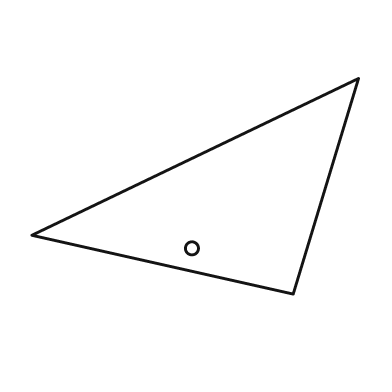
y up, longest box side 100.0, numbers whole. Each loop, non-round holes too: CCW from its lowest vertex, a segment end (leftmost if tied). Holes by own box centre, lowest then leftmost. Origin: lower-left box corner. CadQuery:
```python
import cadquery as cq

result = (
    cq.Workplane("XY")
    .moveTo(80.0, 0.0)
    .lineTo(100.0, 66.0)
    .lineTo(0.0, 18.0)
    .close()
    .moveTo(49.0, 14.0)
    .circle(2.0)
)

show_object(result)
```